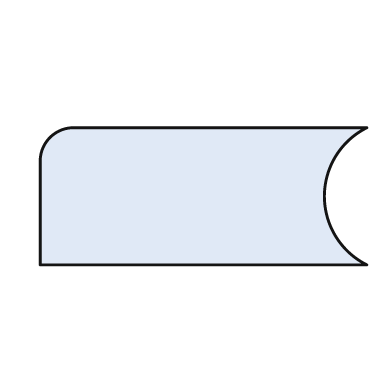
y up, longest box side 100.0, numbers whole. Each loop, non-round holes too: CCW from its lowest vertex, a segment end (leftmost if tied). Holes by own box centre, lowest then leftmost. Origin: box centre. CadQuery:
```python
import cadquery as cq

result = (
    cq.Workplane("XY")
    .moveTo(-50.0, -21.0)
    .lineTo(50.0, -21.0)
    .threePointArc((37.0, 0.0), (50.0, 21.0))
    .lineTo(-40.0, 21.0)
    .threePointArc((-47.0, 18.0), (-50.0, 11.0))
    .close()
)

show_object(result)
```